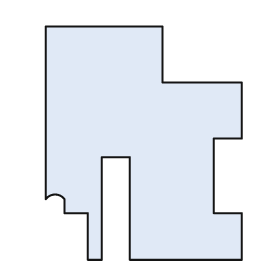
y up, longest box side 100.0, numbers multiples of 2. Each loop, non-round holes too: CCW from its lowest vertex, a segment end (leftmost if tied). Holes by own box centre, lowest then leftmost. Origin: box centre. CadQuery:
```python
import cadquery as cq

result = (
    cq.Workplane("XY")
    .moveTo(-24.0, -50.0)
    .lineTo(-18.0, -50.0)
    .lineTo(-18.0, -6.0)
    .lineTo(-6.0, -6.0)
    .lineTo(-6.0, -50.0)
    .lineTo(42.0, -50.0)
    .lineTo(42.0, -30.0)
    .lineTo(30.0, -30.0)
    .lineTo(30.0, 2.0)
    .lineTo(42.0, 2.0)
    .lineTo(42.0, 26.0)
    .lineTo(8.0, 26.0)
    .lineTo(8.0, 50.0)
    .lineTo(-42.0, 50.0)
    .lineTo(-42.0, -24.0)
    .threePointArc((-38.0, -22.0), (-34.0, -24.0))
    .lineTo(-34.0, -30.0)
    .lineTo(-24.0, -30.0)
    .close()
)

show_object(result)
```